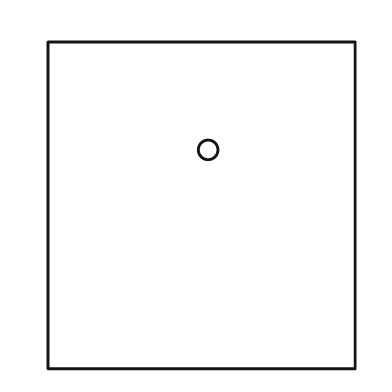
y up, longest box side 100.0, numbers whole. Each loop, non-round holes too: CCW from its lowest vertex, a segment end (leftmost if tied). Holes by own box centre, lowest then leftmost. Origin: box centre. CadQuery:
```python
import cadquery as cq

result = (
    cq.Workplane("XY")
    .moveTo(-47.0, -50.0)
    .lineTo(47.0, -50.0)
    .lineTo(47.0, 50.0)
    .lineTo(-47.0, 50.0)
    .close()
    .moveTo(2.0, 17.0)
    .circle(3.0)
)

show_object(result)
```